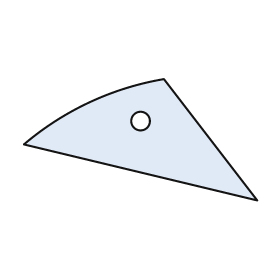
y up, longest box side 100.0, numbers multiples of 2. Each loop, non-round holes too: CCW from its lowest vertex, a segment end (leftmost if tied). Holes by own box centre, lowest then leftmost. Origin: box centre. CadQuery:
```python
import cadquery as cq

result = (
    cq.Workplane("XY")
    .moveTo(50.0, -26.0)
    .lineTo(10.0, 26.0)
    .threePointArc((-22.0, 16.0), (-50.0, -2.0))
    .close()
    .moveTo(0.0, 8.0)
    .circle(4.0)
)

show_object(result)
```